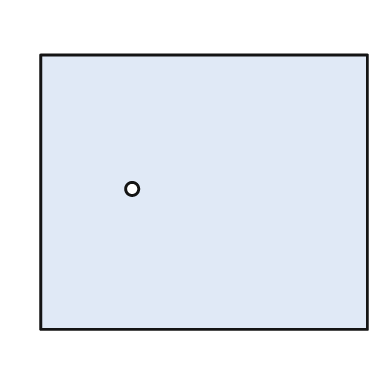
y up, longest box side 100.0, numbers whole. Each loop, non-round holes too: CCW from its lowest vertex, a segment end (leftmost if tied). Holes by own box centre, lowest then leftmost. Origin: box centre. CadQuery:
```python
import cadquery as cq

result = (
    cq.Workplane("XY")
    .moveTo(-50.0, -42.0)
    .lineTo(50.0, -42.0)
    .lineTo(50.0, 42.0)
    .lineTo(-50.0, 42.0)
    .close()
    .moveTo(-22.0, 1.0)
    .circle(2.0)
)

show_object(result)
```